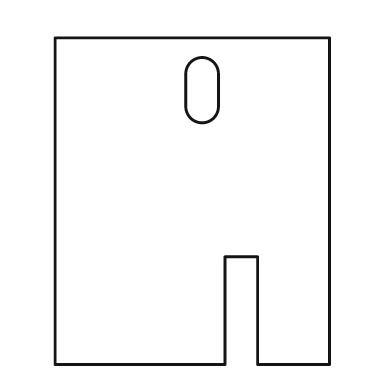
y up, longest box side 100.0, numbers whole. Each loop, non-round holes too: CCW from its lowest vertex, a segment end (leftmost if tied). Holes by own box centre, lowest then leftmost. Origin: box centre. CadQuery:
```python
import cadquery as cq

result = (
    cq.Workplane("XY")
    .moveTo(-42.0, -50.0)
    .lineTo(10.0, -50.0)
    .lineTo(10.0, -17.0)
    .lineTo(20.0, -17.0)
    .lineTo(20.0, -50.0)
    .lineTo(42.0, -50.0)
    .lineTo(42.0, 50.0)
    .lineTo(-42.0, 50.0)
    .close()
    .moveTo(-2.0, 29.0)
    .threePointArc((3.0, 24.0), (8.0, 29.0))
    .lineTo(8.0, 39.0)
    .threePointArc((3.0, 44.0), (-2.0, 39.0))
    .close()
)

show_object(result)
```